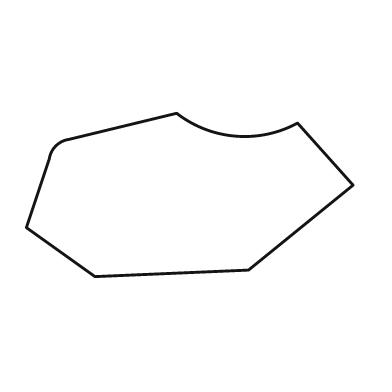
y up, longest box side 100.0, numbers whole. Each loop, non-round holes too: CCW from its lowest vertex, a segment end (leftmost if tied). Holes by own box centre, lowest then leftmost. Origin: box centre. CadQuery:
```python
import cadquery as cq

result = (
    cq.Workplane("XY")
    .moveTo(-29.0, -25.0)
    .lineTo(18.0, -23.0)
    .lineTo(50.0, 3.0)
    .lineTo(33.0, 22.0)
    .threePointArc((14.0, 18.0), (-4.0, 25.0))
    .lineTo(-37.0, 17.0)
    .threePointArc((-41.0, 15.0), (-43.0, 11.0))
    .lineTo(-50.0, -10.0)
    .close()
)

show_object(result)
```